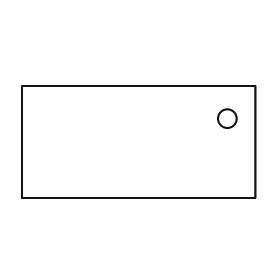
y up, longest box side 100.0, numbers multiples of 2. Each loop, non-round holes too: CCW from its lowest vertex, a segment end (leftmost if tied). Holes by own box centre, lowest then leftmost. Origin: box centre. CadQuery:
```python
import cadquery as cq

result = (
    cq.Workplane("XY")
    .moveTo(-50.0, -24.0)
    .lineTo(50.0, -24.0)
    .lineTo(50.0, 24.0)
    .lineTo(-50.0, 24.0)
    .close()
    .moveTo(38.0, 10.0)
    .circle(4.0)
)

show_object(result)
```